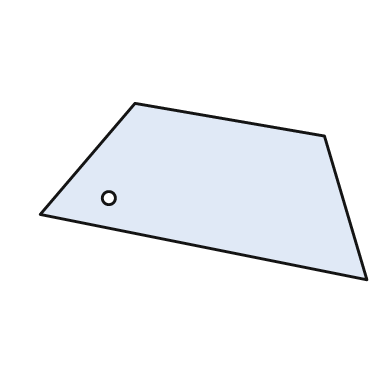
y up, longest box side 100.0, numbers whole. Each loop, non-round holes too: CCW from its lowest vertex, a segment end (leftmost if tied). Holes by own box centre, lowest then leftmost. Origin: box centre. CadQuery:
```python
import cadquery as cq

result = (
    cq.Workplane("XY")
    .moveTo(50.0, -27.0)
    .lineTo(37.0, 17.0)
    .lineTo(-21.0, 27.0)
    .lineTo(-50.0, -7.0)
    .close()
    .moveTo(-29.0, -2.0)
    .circle(2.0)
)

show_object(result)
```